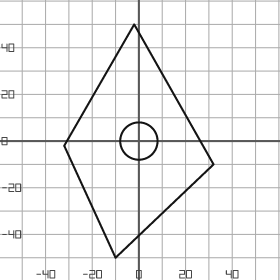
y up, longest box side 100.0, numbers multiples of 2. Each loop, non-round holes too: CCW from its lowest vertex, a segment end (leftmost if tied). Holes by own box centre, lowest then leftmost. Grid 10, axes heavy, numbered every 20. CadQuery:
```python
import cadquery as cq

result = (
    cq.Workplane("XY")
    .moveTo(-10.0, -50.0)
    .lineTo(32.0, -10.0)
    .lineTo(-2.0, 50.0)
    .lineTo(-32.0, -2.0)
    .close()
    .moveTo(0.0, 0.0)
    .circle(8.0)
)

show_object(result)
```